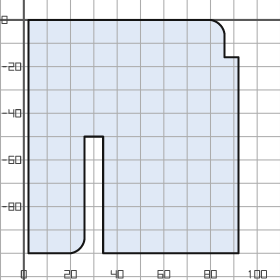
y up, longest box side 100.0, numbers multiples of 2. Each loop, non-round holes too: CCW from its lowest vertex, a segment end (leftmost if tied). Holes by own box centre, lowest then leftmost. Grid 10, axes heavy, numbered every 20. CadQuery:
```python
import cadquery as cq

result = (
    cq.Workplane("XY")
    .moveTo(2.0, -100.0)
    .lineTo(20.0, -100.0)
    .threePointArc((24.0, -98.0), (26.0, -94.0))
    .lineTo(26.0, -50.0)
    .lineTo(34.0, -50.0)
    .lineTo(34.0, -100.0)
    .lineTo(92.0, -100.0)
    .lineTo(92.0, -16.0)
    .lineTo(86.0, -16.0)
    .lineTo(86.0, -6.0)
    .threePointArc((84.0, -2.0), (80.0, 0.0))
    .lineTo(2.0, 0.0)
    .close()
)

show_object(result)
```